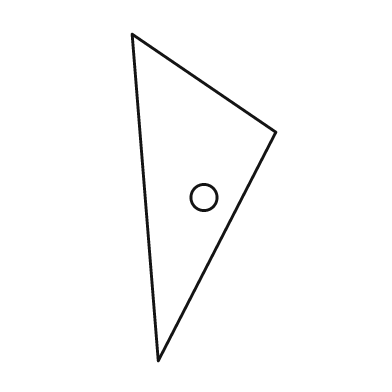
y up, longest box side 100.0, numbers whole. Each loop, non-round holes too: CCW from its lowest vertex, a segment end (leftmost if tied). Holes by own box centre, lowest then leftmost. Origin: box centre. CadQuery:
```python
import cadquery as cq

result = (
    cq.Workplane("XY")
    .moveTo(-14.0, -50.0)
    .lineTo(22.0, 20.0)
    .lineTo(-22.0, 50.0)
    .close()
    .moveTo(0.0, 0.0)
    .circle(4.0)
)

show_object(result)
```